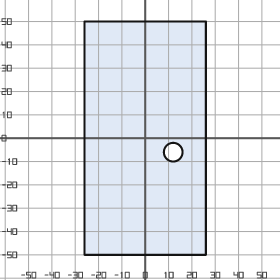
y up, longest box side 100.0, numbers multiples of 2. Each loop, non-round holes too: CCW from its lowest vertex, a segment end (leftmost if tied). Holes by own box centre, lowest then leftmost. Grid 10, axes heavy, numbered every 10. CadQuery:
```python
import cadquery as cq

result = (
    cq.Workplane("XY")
    .moveTo(-26.0, -50.0)
    .lineTo(26.0, -50.0)
    .lineTo(26.0, 50.0)
    .lineTo(-26.0, 50.0)
    .close()
    .moveTo(12.0, -6.0)
    .circle(4.0)
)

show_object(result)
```